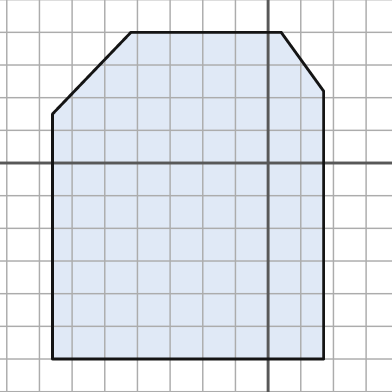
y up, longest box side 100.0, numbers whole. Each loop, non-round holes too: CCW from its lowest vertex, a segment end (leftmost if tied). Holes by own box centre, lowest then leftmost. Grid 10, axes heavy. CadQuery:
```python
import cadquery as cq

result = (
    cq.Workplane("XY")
    .moveTo(-66.0, -60.0)
    .lineTo(17.0, -60.0)
    .lineTo(17.0, 22.0)
    .lineTo(4.0, 40.0)
    .lineTo(-42.0, 40.0)
    .lineTo(-66.0, 15.0)
    .close()
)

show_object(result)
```